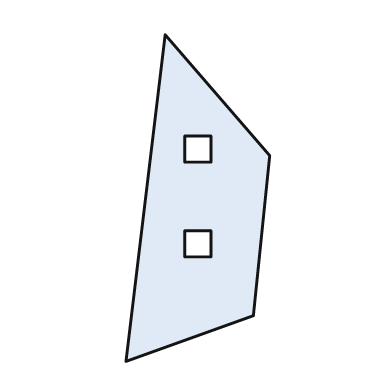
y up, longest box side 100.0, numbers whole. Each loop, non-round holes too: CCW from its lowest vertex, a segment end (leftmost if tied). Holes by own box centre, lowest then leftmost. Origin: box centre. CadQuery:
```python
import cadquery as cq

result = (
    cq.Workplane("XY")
    .moveTo(-22.0, -50.0)
    .lineTo(17.0, -36.0)
    .lineTo(22.0, 13.0)
    .lineTo(-10.0, 50.0)
    .close()
    .moveTo(-4.0, -18.0)
    .lineTo(4.0, -18.0)
    .lineTo(4.0, -10.0)
    .lineTo(-4.0, -10.0)
    .close()
    .moveTo(-4.0, 11.0)
    .lineTo(4.0, 11.0)
    .lineTo(4.0, 19.0)
    .lineTo(-4.0, 19.0)
    .close()
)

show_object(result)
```